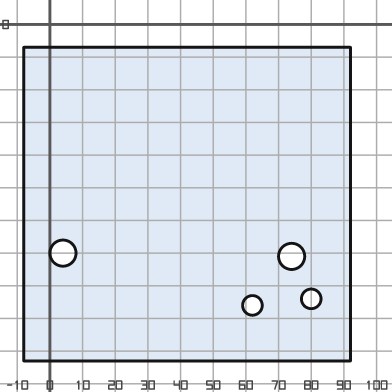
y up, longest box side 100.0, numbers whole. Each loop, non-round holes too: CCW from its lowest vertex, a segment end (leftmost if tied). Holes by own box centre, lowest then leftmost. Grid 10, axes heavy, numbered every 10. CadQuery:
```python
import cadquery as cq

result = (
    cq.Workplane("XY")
    .moveTo(-8.0, -103.0)
    .lineTo(92.0, -103.0)
    .lineTo(92.0, -7.0)
    .lineTo(-8.0, -7.0)
    .close()
    .moveTo(62.0, -86.0)
    .circle(3.0)
    .moveTo(80.0, -84.0)
    .circle(3.0)
    .moveTo(74.0, -71.0)
    .circle(4.0)
    .moveTo(4.0, -70.0)
    .circle(4.0)
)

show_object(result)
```